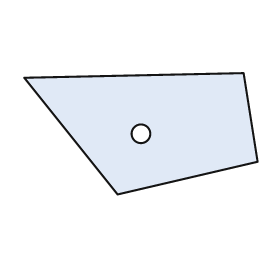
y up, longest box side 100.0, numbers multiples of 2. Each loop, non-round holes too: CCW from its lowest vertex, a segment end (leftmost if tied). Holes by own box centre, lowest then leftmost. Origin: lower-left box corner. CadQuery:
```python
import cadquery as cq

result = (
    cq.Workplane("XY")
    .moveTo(40.0, 0.0)
    .lineTo(100.0, 14.0)
    .lineTo(94.0, 52.0)
    .lineTo(0.0, 50.0)
    .close()
    .moveTo(50.0, 26.0)
    .circle(4.0)
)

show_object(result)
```